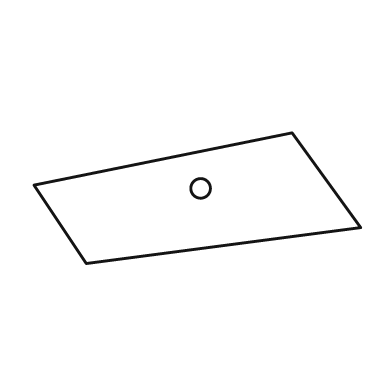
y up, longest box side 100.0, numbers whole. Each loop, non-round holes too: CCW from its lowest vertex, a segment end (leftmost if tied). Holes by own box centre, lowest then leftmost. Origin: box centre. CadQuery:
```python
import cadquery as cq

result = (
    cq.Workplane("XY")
    .moveTo(-34.0, -20.0)
    .lineTo(50.0, -9.0)
    .lineTo(29.0, 20.0)
    .lineTo(-50.0, 4.0)
    .close()
    .moveTo(1.0, 3.0)
    .circle(3.0)
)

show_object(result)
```